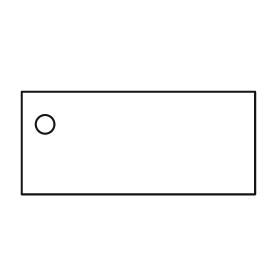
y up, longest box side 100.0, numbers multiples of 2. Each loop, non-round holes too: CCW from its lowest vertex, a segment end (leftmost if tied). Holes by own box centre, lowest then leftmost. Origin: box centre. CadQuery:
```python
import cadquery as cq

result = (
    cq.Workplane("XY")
    .moveTo(-50.0, -22.0)
    .lineTo(50.0, -22.0)
    .lineTo(50.0, 22.0)
    .lineTo(-50.0, 22.0)
    .close()
    .moveTo(-40.0, 8.0)
    .circle(4.0)
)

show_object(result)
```